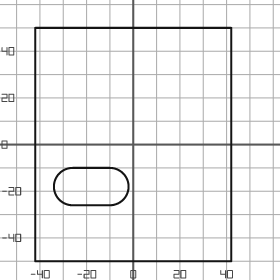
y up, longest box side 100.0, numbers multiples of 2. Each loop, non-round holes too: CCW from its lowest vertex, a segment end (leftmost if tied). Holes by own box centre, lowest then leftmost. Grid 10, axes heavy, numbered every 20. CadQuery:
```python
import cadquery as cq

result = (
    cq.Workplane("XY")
    .moveTo(-42.0, -50.0)
    .lineTo(42.0, -50.0)
    .lineTo(42.0, 50.0)
    .lineTo(-42.0, 50.0)
    .close()
    .moveTo(-26.0, -26.0)
    .lineTo(-10.0, -26.0)
    .threePointArc((-2.0, -18.0), (-10.0, -10.0))
    .lineTo(-26.0, -10.0)
    .threePointArc((-34.0, -18.0), (-26.0, -26.0))
    .close()
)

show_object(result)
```